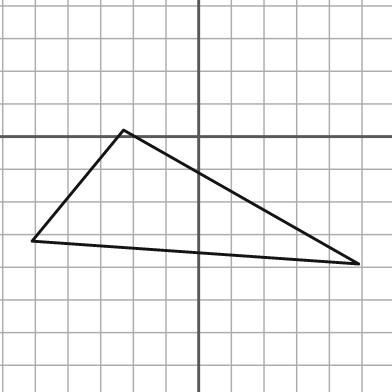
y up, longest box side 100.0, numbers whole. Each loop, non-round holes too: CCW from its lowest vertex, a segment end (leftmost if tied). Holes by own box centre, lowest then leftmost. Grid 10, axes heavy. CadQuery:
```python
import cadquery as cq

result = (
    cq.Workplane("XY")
    .moveTo(49.0, -39.0)
    .lineTo(-23.0, 2.0)
    .lineTo(-51.0, -32.0)
    .close()
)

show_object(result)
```